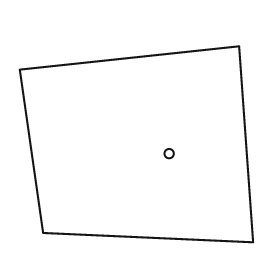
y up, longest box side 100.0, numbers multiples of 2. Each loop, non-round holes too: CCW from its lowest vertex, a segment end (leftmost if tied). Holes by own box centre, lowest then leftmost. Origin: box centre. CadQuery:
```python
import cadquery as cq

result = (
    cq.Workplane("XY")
    .moveTo(50.0, -42.0)
    .lineTo(44.0, 42.0)
    .lineTo(-50.0, 32.0)
    .lineTo(-40.0, -38.0)
    .close()
    .moveTo(14.0, -4.0)
    .circle(2.0)
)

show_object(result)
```